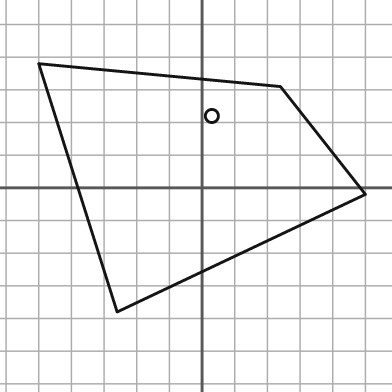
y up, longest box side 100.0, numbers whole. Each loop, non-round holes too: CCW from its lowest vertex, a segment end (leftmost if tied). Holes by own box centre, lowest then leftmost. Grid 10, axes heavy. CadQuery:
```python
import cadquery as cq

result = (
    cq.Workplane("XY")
    .moveTo(-26.0, -38.0)
    .lineTo(50.0, -2.0)
    .lineTo(24.0, 31.0)
    .lineTo(-50.0, 38.0)
    .close()
    .moveTo(3.0, 22.0)
    .circle(2.0)
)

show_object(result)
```